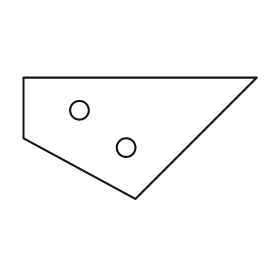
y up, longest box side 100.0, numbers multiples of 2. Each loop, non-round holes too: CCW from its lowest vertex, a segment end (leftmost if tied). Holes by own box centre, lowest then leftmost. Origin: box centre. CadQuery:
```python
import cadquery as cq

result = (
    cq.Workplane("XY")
    .moveTo(-2.0, -26.0)
    .lineTo(50.0, 26.0)
    .lineTo(-50.0, 26.0)
    .lineTo(-50.0, 0.0)
    .close()
    .moveTo(-6.0, -4.0)
    .circle(4.0)
    .moveTo(-26.0, 12.0)
    .circle(4.0)
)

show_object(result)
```